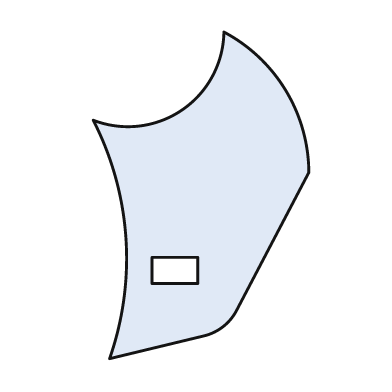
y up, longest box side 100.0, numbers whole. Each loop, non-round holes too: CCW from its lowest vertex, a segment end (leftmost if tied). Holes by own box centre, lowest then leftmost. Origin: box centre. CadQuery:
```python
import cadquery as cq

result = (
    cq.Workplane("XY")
    .moveTo(-28.0, -50.0)
    .lineTo(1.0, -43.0)
    .threePointArc((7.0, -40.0), (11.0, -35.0))
    .lineTo(33.0, 7.0)
    .threePointArc((26.0, 32.0), (7.0, 50.0))
    .threePointArc((-6.0, 26.0), (-33.0, 23.0))
    .threePointArc((-23.0, -13.0), (-28.0, -50.0))
    .close()
    .moveTo(-15.0, -27.0)
    .lineTo(-1.0, -27.0)
    .lineTo(-1.0, -19.0)
    .lineTo(-15.0, -19.0)
    .close()
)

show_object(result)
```